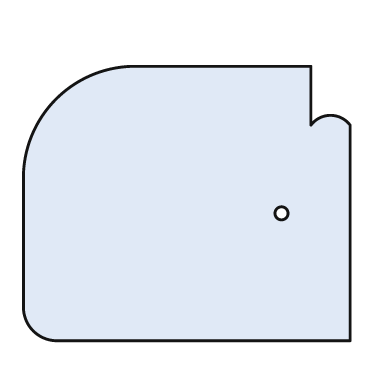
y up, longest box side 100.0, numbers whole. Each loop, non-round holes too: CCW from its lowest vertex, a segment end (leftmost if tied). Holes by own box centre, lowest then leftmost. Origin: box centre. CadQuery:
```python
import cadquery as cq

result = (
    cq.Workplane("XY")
    .moveTo(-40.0, -42.0)
    .lineTo(50.0, -42.0)
    .lineTo(50.0, 24.0)
    .threePointArc((44.0, 27.0), (38.0, 24.0))
    .lineTo(38.0, 42.0)
    .lineTo(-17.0, 42.0)
    .threePointArc((-40.0, 32.0), (-50.0, 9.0))
    .lineTo(-50.0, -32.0)
    .threePointArc((-47.0, -39.0), (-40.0, -42.0))
    .close()
    .moveTo(29.0, -3.0)
    .circle(2.0)
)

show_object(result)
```